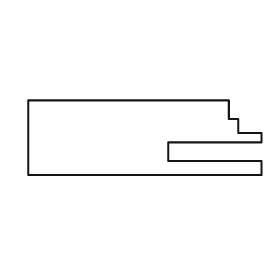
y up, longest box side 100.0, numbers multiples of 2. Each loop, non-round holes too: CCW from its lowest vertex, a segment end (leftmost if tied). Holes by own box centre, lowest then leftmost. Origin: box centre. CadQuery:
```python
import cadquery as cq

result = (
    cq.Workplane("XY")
    .moveTo(-50.0, -16.0)
    .lineTo(50.0, -16.0)
    .lineTo(50.0, -10.0)
    .lineTo(10.0, -10.0)
    .lineTo(10.0, -2.0)
    .lineTo(50.0, -2.0)
    .lineTo(50.0, 2.0)
    .lineTo(40.0, 2.0)
    .lineTo(40.0, 8.0)
    .lineTo(36.0, 8.0)
    .lineTo(36.0, 16.0)
    .lineTo(-50.0, 16.0)
    .close()
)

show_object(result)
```